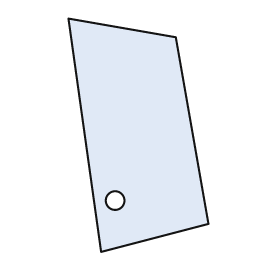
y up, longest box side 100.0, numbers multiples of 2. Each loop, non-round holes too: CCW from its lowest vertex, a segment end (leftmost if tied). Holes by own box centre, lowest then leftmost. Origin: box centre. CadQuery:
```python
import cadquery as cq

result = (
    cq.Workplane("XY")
    .moveTo(-16.0, -50.0)
    .lineTo(30.0, -38.0)
    .lineTo(16.0, 42.0)
    .lineTo(-30.0, 50.0)
    .close()
    .moveTo(-10.0, -28.0)
    .circle(4.0)
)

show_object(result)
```